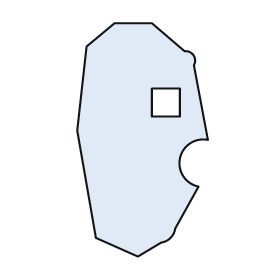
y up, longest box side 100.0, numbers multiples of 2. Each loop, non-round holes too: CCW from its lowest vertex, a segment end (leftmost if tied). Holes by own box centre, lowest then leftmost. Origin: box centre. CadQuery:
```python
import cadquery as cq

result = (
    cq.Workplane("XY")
    .moveTo(-2.0, -50.0)
    .lineTo(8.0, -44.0)
    .threePointArc((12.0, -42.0), (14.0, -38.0))
    .lineTo(24.0, -20.0)
    .threePointArc((16.0, -8.0), (28.0, 0.0))
    .lineTo(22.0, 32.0)
    .threePointArc((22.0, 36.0), (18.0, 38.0))
    .lineTo(4.0, 50.0)
    .lineTo(-12.0, 50.0)
    .lineTo(-24.0, 40.0)
    .lineTo(-28.0, 4.0)
    .lineTo(-20.0, -42.0)
    .close()
    .moveTo(4.0, 10.0)
    .lineTo(16.0, 10.0)
    .lineTo(16.0, 22.0)
    .lineTo(4.0, 22.0)
    .close()
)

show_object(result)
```